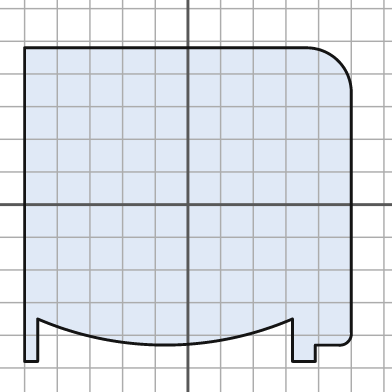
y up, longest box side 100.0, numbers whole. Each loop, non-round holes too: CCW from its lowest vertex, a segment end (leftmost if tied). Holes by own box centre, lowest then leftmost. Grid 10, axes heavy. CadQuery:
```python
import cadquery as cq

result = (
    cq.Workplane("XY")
    .moveTo(-50.0, -48.0)
    .lineTo(-46.0, -48.0)
    .lineTo(-46.0, -35.0)
    .threePointArc((-7.0, -43.0), (32.0, -35.0))
    .lineTo(32.0, -48.0)
    .lineTo(39.0, -48.0)
    .lineTo(39.0, -43.0)
    .lineTo(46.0, -43.0)
    .threePointArc((49.0, -42.0), (50.0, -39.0))
    .lineTo(50.0, 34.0)
    .threePointArc((46.0, 44.0), (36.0, 48.0))
    .lineTo(-50.0, 48.0)
    .close()
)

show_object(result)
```